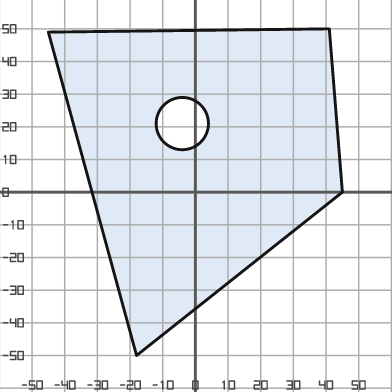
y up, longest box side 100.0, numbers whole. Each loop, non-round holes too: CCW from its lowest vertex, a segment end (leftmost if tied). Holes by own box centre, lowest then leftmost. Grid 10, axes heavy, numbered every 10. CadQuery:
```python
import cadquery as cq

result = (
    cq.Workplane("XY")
    .moveTo(-18.0, -50.0)
    .lineTo(45.0, 0.0)
    .lineTo(41.0, 50.0)
    .lineTo(-45.0, 49.0)
    .close()
    .moveTo(-4.0, 21.0)
    .circle(8.0)
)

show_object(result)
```